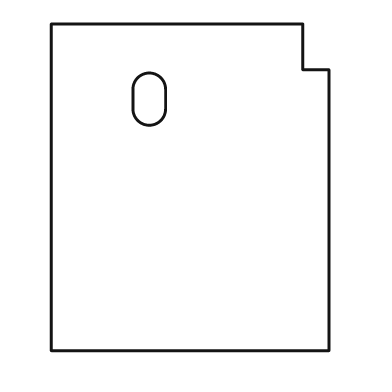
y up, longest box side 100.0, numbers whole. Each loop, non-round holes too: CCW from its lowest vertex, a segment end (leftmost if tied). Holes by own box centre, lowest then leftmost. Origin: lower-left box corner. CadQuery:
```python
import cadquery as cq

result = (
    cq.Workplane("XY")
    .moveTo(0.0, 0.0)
    .lineTo(85.0, 0.0)
    .lineTo(85.0, 86.0)
    .lineTo(77.0, 86.0)
    .lineTo(77.0, 100.0)
    .lineTo(0.0, 100.0)
    .close()
    .moveTo(25.0, 74.0)
    .threePointArc((30.0, 69.0), (35.0, 74.0))
    .lineTo(35.0, 80.0)
    .threePointArc((30.0, 85.0), (25.0, 80.0))
    .close()
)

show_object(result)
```